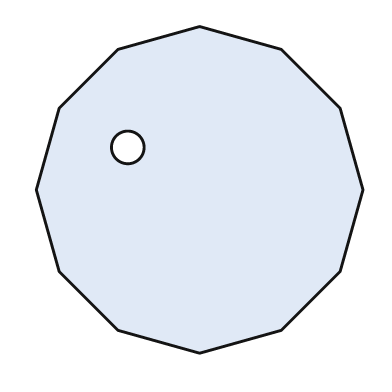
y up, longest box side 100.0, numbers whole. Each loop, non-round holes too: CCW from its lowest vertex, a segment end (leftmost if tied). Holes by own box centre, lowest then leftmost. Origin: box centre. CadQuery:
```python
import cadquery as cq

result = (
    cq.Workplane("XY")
    .moveTo(0.0, -50.0)
    .lineTo(25.0, -43.0)
    .lineTo(43.0, -25.0)
    .lineTo(50.0, 0.0)
    .lineTo(43.0, 25.0)
    .lineTo(25.0, 43.0)
    .lineTo(0.0, 50.0)
    .lineTo(-25.0, 43.0)
    .lineTo(-43.0, 25.0)
    .lineTo(-50.0, 0.0)
    .lineTo(-43.0, -25.0)
    .lineTo(-25.0, -43.0)
    .close()
    .moveTo(-22.0, 13.0)
    .circle(5.0)
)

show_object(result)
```